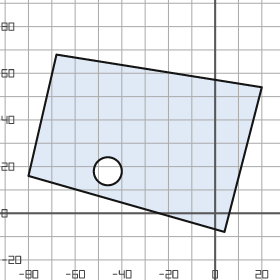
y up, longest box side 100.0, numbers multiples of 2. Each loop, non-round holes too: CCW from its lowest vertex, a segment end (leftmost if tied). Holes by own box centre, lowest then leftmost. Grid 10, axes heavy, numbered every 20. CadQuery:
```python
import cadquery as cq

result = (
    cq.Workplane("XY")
    .moveTo(4.0, -8.0)
    .lineTo(20.0, 54.0)
    .lineTo(-68.0, 68.0)
    .lineTo(-80.0, 16.0)
    .close()
    .moveTo(-46.0, 18.0)
    .circle(6.0)
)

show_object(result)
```